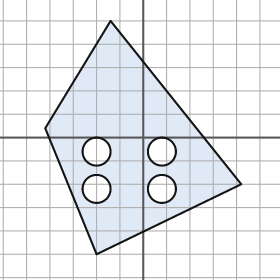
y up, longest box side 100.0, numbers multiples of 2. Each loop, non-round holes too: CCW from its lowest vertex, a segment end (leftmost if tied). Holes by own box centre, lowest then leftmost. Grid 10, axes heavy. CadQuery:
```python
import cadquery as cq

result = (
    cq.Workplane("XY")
    .moveTo(-20.0, -50.0)
    .lineTo(42.0, -20.0)
    .lineTo(-14.0, 50.0)
    .lineTo(-42.0, 4.0)
    .close()
    .moveTo(-20.0, -22.0)
    .circle(6.0)
    .moveTo(8.0, -22.0)
    .circle(6.0)
    .moveTo(-20.0, -6.0)
    .circle(6.0)
    .moveTo(8.0, -6.0)
    .circle(6.0)
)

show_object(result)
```